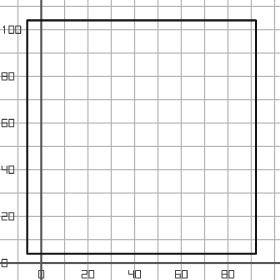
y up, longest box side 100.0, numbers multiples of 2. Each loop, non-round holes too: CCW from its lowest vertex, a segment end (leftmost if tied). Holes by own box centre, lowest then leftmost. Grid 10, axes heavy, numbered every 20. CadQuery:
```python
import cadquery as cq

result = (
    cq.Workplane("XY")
    .moveTo(-6.0, 4.0)
    .lineTo(92.0, 4.0)
    .lineTo(92.0, 104.0)
    .lineTo(-6.0, 104.0)
    .close()
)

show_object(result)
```